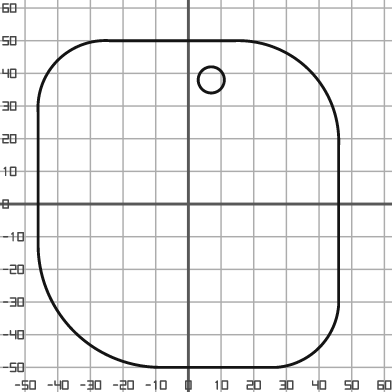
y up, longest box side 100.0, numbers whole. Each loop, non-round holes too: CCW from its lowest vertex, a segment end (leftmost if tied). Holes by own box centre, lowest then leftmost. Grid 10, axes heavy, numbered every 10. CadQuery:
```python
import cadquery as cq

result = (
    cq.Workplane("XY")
    .moveTo(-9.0, -50.0)
    .lineTo(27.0, -50.0)
    .threePointArc((40.0, -44.0), (46.0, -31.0))
    .lineTo(46.0, 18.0)
    .threePointArc((37.0, 41.0), (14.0, 50.0))
    .lineTo(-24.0, 50.0)
    .threePointArc((-40.0, 44.0), (-46.0, 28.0))
    .lineTo(-46.0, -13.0)
    .threePointArc((-35.0, -39.0), (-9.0, -50.0))
    .close()
    .moveTo(7.0, 38.0)
    .circle(4.0)
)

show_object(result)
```